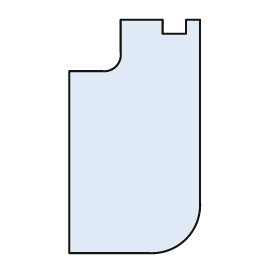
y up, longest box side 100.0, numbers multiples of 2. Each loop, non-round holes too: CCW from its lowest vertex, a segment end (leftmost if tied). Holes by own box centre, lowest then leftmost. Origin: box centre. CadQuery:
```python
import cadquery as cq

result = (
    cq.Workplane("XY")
    .moveTo(-28.0, -50.0)
    .lineTo(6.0, -50.0)
    .threePointArc((22.0, -44.0), (28.0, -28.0))
    .lineTo(28.0, 50.0)
    .lineTo(22.0, 50.0)
    .lineTo(22.0, 44.0)
    .lineTo(12.0, 44.0)
    .lineTo(12.0, 50.0)
    .lineTo(-6.0, 50.0)
    .lineTo(-6.0, 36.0)
    .threePointArc((-8.0, 30.0), (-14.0, 28.0))
    .lineTo(-28.0, 28.0)
    .close()
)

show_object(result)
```